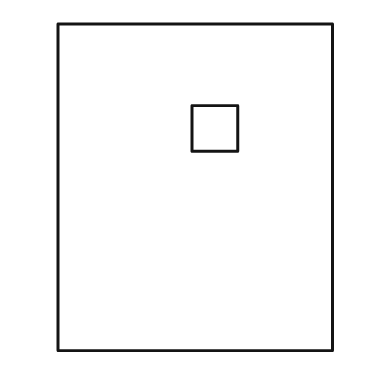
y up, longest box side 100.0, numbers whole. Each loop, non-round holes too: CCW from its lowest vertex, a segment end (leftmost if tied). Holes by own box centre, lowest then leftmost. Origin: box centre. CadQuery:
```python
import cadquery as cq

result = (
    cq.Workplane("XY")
    .moveTo(-42.0, -50.0)
    .lineTo(42.0, -50.0)
    .lineTo(42.0, 50.0)
    .lineTo(-42.0, 50.0)
    .close()
    .moveTo(-1.0, 11.0)
    .lineTo(13.0, 11.0)
    .lineTo(13.0, 25.0)
    .lineTo(-1.0, 25.0)
    .close()
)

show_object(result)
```